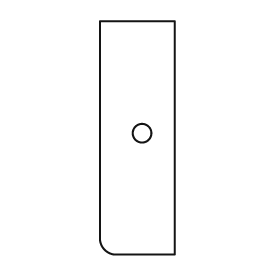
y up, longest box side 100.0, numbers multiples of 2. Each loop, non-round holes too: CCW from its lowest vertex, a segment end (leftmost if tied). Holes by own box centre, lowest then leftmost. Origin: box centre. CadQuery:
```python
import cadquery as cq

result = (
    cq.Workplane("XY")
    .moveTo(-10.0, -50.0)
    .lineTo(16.0, -50.0)
    .lineTo(16.0, 50.0)
    .lineTo(-16.0, 50.0)
    .lineTo(-16.0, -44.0)
    .threePointArc((-14.0, -48.0), (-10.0, -50.0))
    .close()
    .moveTo(2.0, 2.0)
    .circle(4.0)
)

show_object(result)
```